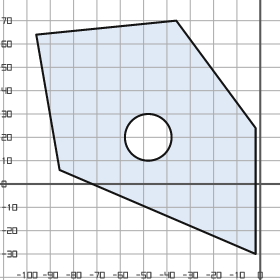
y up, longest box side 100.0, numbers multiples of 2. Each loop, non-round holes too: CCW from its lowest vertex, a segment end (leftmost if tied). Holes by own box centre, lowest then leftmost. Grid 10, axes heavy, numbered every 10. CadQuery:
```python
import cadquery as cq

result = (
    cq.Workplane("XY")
    .moveTo(-2.0, -30.0)
    .lineTo(-2.0, 24.0)
    .lineTo(-36.0, 70.0)
    .lineTo(-96.0, 64.0)
    .lineTo(-86.0, 6.0)
    .close()
    .moveTo(-48.0, 20.0)
    .circle(10.0)
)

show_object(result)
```